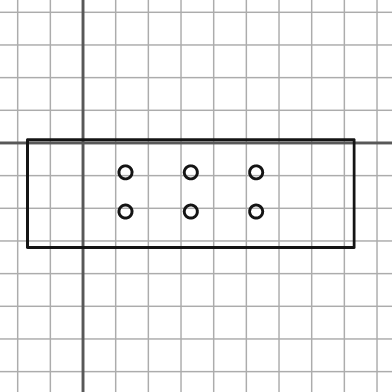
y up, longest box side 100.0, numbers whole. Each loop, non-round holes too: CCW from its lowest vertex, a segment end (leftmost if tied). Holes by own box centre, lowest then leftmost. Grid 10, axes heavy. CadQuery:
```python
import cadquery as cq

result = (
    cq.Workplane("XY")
    .moveTo(-17.0, -32.0)
    .lineTo(83.0, -32.0)
    .lineTo(83.0, 1.0)
    .lineTo(-17.0, 1.0)
    .close()
    .moveTo(13.0, -21.0)
    .circle(2.0)
    .moveTo(33.0, -21.0)
    .circle(2.0)
    .moveTo(53.0, -21.0)
    .circle(2.0)
    .moveTo(13.0, -9.0)
    .circle(2.0)
    .moveTo(33.0, -9.0)
    .circle(2.0)
    .moveTo(53.0, -9.0)
    .circle(2.0)
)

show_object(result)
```